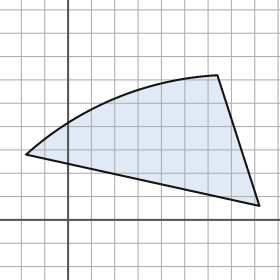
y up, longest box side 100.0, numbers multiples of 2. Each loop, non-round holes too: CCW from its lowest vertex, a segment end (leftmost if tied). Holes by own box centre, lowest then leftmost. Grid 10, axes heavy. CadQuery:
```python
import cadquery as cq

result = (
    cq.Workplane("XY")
    .moveTo(82.0, 6.0)
    .lineTo(64.0, 62.0)
    .threePointArc((20.0, 52.0), (-18.0, 28.0))
    .close()
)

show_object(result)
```